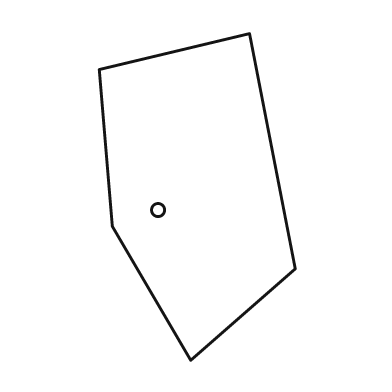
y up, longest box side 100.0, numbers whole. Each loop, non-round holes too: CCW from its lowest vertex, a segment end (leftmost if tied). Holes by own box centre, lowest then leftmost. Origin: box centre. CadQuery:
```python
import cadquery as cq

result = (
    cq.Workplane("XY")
    .moveTo(-2.0, -50.0)
    .lineTo(30.0, -22.0)
    .lineTo(16.0, 50.0)
    .lineTo(-30.0, 39.0)
    .lineTo(-26.0, -9.0)
    .close()
    .moveTo(-12.0, -4.0)
    .circle(2.0)
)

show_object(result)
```